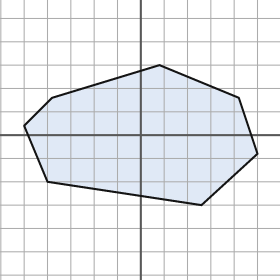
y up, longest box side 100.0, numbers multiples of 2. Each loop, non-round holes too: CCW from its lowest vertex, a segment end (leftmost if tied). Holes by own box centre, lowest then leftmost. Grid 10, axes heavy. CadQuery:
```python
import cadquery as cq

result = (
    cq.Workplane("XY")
    .moveTo(26.0, -30.0)
    .lineTo(50.0, -8.0)
    .lineTo(42.0, 16.0)
    .lineTo(8.0, 30.0)
    .lineTo(-38.0, 16.0)
    .lineTo(-50.0, 4.0)
    .lineTo(-40.0, -20.0)
    .close()
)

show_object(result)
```